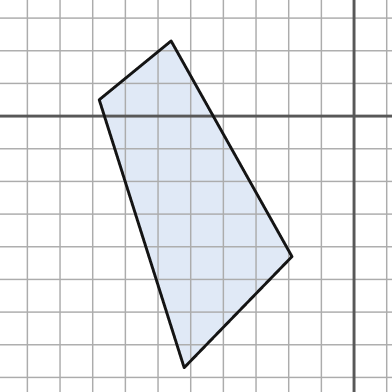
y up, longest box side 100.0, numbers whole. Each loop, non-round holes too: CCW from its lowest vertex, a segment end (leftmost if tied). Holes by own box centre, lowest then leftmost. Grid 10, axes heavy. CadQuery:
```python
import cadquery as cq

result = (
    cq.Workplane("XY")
    .moveTo(-52.0, -77.0)
    .lineTo(-19.0, -43.0)
    .lineTo(-56.0, 23.0)
    .lineTo(-78.0, 5.0)
    .close()
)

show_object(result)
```